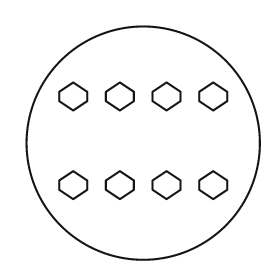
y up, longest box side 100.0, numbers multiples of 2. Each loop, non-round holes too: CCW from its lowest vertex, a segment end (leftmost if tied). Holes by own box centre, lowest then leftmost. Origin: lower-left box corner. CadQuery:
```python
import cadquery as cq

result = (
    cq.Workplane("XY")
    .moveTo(50.0, 50.0)
    .circle(50.0)
    .moveTo(20.0, 26.0)
    .lineTo(26.0, 30.0)
    .lineTo(26.0, 34.0)
    .lineTo(20.0, 38.0)
    .lineTo(14.0, 34.0)
    .lineTo(14.0, 30.0)
    .close()
    .moveTo(40.0, 26.0)
    .lineTo(46.0, 30.0)
    .lineTo(46.0, 34.0)
    .lineTo(40.0, 38.0)
    .lineTo(34.0, 34.0)
    .lineTo(34.0, 30.0)
    .close()
    .moveTo(60.0, 26.0)
    .lineTo(66.0, 30.0)
    .lineTo(66.0, 34.0)
    .lineTo(60.0, 38.0)
    .lineTo(54.0, 34.0)
    .lineTo(54.0, 30.0)
    .close()
    .moveTo(80.0, 26.0)
    .lineTo(86.0, 30.0)
    .lineTo(86.0, 34.0)
    .lineTo(80.0, 38.0)
    .lineTo(74.0, 34.0)
    .lineTo(74.0, 30.0)
    .close()
    .moveTo(20.0, 64.0)
    .lineTo(26.0, 68.0)
    .lineTo(26.0, 72.0)
    .lineTo(20.0, 76.0)
    .lineTo(14.0, 72.0)
    .lineTo(14.0, 68.0)
    .close()
    .moveTo(40.0, 64.0)
    .lineTo(46.0, 68.0)
    .lineTo(46.0, 72.0)
    .lineTo(40.0, 76.0)
    .lineTo(34.0, 72.0)
    .lineTo(34.0, 68.0)
    .close()
    .moveTo(60.0, 64.0)
    .lineTo(66.0, 68.0)
    .lineTo(66.0, 72.0)
    .lineTo(60.0, 76.0)
    .lineTo(54.0, 72.0)
    .lineTo(54.0, 68.0)
    .close()
    .moveTo(80.0, 64.0)
    .lineTo(86.0, 68.0)
    .lineTo(86.0, 72.0)
    .lineTo(80.0, 76.0)
    .lineTo(74.0, 72.0)
    .lineTo(74.0, 68.0)
    .close()
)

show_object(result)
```